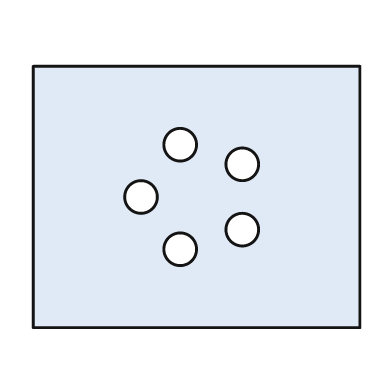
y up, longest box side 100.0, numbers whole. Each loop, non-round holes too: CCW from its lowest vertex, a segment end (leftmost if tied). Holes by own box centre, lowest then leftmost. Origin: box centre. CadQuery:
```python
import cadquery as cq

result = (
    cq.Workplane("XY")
    .moveTo(-50.0, -40.0)
    .lineTo(50.0, -40.0)
    .lineTo(50.0, 40.0)
    .lineTo(-50.0, 40.0)
    .close()
    .moveTo(-5.0, -16.0)
    .circle(5.0)
    .moveTo(14.0, -10.0)
    .circle(5.0)
    .moveTo(-17.0, 0.0)
    .circle(5.0)
    .moveTo(14.0, 10.0)
    .circle(5.0)
    .moveTo(-5.0, 16.0)
    .circle(5.0)
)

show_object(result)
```